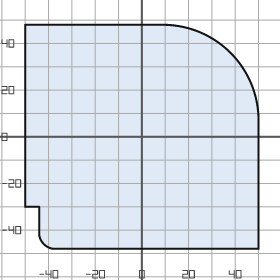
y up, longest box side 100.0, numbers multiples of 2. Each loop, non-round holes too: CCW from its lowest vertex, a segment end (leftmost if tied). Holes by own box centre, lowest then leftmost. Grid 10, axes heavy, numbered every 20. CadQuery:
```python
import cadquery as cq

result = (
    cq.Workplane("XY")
    .moveTo(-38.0, -48.0)
    .lineTo(50.0, -48.0)
    .lineTo(50.0, 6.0)
    .threePointArc((38.0, 36.0), (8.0, 48.0))
    .lineTo(-50.0, 48.0)
    .lineTo(-50.0, -30.0)
    .lineTo(-44.0, -30.0)
    .lineTo(-44.0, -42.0)
    .threePointArc((-42.0, -46.0), (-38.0, -48.0))
    .close()
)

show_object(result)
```